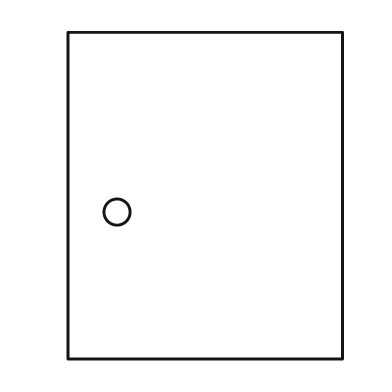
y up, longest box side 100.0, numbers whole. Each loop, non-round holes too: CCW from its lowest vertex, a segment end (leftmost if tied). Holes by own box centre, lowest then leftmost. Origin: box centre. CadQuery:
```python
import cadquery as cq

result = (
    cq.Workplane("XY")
    .moveTo(-42.0, -50.0)
    .lineTo(42.0, -50.0)
    .lineTo(42.0, 50.0)
    .lineTo(-42.0, 50.0)
    .close()
    .moveTo(-27.0, -5.0)
    .circle(4.0)
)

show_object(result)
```